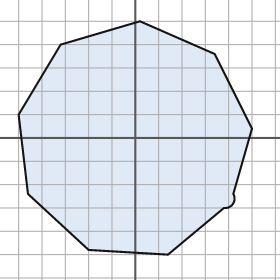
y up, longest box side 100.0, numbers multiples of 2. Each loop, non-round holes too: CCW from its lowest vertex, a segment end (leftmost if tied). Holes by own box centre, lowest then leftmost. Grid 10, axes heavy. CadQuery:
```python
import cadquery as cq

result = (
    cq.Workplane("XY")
    .moveTo(14.0, -50.0)
    .lineTo(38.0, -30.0)
    .threePointArc((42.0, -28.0), (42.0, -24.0))
    .lineTo(50.0, 4.0)
    .lineTo(34.0, 36.0)
    .lineTo(2.0, 50.0)
    .lineTo(-32.0, 40.0)
    .lineTo(-50.0, 10.0)
    .lineTo(-46.0, -24.0)
    .lineTo(-20.0, -48.0)
    .close()
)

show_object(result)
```